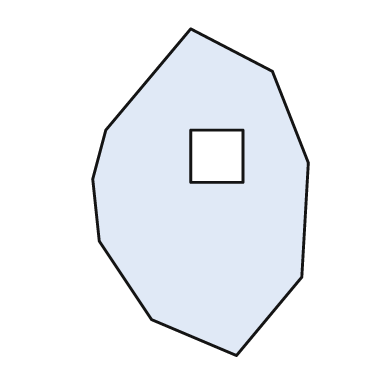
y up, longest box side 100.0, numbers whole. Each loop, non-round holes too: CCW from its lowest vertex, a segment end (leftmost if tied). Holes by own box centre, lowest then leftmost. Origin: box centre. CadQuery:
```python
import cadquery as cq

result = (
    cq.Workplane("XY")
    .moveTo(11.0, -50.0)
    .lineTo(31.0, -26.0)
    .lineTo(33.0, 9.0)
    .lineTo(22.0, 37.0)
    .lineTo(-3.0, 50.0)
    .lineTo(-29.0, 19.0)
    .lineTo(-33.0, 4.0)
    .lineTo(-31.0, -15.0)
    .lineTo(-15.0, -39.0)
    .close()
    .moveTo(-3.0, 3.0)
    .lineTo(13.0, 3.0)
    .lineTo(13.0, 19.0)
    .lineTo(-3.0, 19.0)
    .close()
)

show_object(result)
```